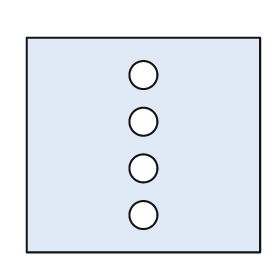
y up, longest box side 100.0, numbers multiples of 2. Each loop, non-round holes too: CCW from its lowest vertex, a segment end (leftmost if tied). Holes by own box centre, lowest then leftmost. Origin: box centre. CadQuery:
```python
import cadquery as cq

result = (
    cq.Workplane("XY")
    .moveTo(-50.0, -46.0)
    .lineTo(50.0, -46.0)
    .lineTo(50.0, 46.0)
    .lineTo(-50.0, 46.0)
    .close()
    .moveTo(0.0, -30.0)
    .circle(6.0)
    .moveTo(0.0, -10.0)
    .circle(6.0)
    .moveTo(0.0, 10.0)
    .circle(6.0)
    .moveTo(0.0, 30.0)
    .circle(6.0)
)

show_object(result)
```